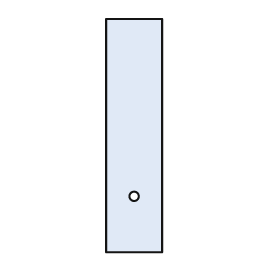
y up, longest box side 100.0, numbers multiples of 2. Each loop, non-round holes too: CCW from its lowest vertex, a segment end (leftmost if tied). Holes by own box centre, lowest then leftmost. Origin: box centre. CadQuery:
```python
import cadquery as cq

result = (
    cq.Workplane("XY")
    .moveTo(-12.0, -50.0)
    .lineTo(12.0, -50.0)
    .lineTo(12.0, 50.0)
    .lineTo(-12.0, 50.0)
    .close()
    .moveTo(0.0, -26.0)
    .circle(2.0)
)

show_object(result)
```